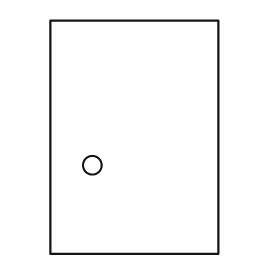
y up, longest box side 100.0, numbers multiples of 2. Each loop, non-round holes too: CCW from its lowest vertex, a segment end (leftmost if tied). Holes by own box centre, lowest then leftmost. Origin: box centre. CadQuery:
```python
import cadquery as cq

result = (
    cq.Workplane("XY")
    .moveTo(-36.0, -50.0)
    .lineTo(36.0, -50.0)
    .lineTo(36.0, 50.0)
    .lineTo(-36.0, 50.0)
    .close()
    .moveTo(-18.0, -12.0)
    .circle(4.0)
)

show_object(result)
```